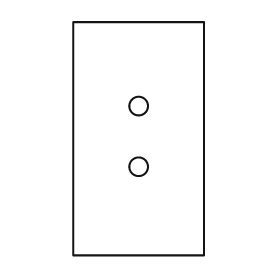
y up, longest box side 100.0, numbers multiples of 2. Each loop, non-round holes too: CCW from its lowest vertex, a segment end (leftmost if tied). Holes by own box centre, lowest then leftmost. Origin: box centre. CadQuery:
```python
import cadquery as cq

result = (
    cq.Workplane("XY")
    .moveTo(-28.0, -50.0)
    .lineTo(28.0, -50.0)
    .lineTo(28.0, 50.0)
    .lineTo(-28.0, 50.0)
    .close()
    .moveTo(0.0, -12.0)
    .circle(4.0)
    .moveTo(0.0, 14.0)
    .circle(4.0)
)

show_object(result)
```